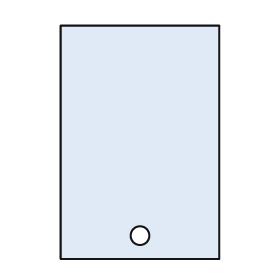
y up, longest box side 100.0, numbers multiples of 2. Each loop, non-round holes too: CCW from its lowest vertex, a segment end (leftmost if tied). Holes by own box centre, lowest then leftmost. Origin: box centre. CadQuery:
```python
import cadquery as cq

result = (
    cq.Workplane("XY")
    .moveTo(-34.0, -50.0)
    .lineTo(34.0, -50.0)
    .lineTo(34.0, 50.0)
    .lineTo(-34.0, 50.0)
    .close()
    .moveTo(0.0, -40.0)
    .circle(4.0)
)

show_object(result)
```